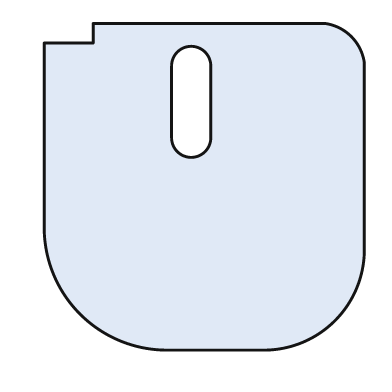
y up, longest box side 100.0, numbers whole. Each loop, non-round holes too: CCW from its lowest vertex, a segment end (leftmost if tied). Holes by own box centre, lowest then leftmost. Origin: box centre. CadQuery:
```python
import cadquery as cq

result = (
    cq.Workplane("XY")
    .moveTo(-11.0, -50.0)
    .lineTo(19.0, -50.0)
    .threePointArc((40.0, -41.0), (49.0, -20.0))
    .lineTo(49.0, 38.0)
    .threePointArc((45.0, 46.0), (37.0, 50.0))
    .lineTo(-34.0, 50.0)
    .lineTo(-34.0, 44.0)
    .lineTo(-49.0, 44.0)
    .lineTo(-49.0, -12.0)
    .threePointArc((-38.0, -39.0), (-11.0, -50.0))
    .close()
    .moveTo(-10.0, 15.0)
    .threePointArc((-4.0, 9.0), (2.0, 15.0))
    .lineTo(2.0, 37.0)
    .threePointArc((-4.0, 43.0), (-10.0, 37.0))
    .close()
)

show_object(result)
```